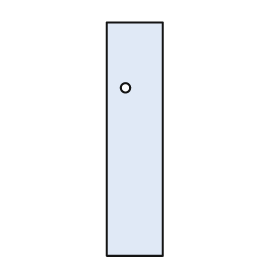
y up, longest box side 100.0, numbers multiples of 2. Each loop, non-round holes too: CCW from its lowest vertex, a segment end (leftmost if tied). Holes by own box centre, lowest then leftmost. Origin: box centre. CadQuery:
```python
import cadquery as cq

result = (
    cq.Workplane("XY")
    .moveTo(-12.0, -50.0)
    .lineTo(12.0, -50.0)
    .lineTo(12.0, 50.0)
    .lineTo(-12.0, 50.0)
    .close()
    .moveTo(-4.0, 22.0)
    .circle(2.0)
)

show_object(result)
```